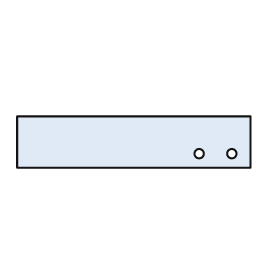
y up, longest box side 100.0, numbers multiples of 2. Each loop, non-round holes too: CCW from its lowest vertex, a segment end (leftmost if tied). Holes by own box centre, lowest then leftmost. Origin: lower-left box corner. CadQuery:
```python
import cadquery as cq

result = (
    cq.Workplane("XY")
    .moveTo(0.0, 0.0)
    .lineTo(100.0, 0.0)
    .lineTo(100.0, 22.0)
    .lineTo(0.0, 22.0)
    .close()
    .moveTo(78.0, 6.0)
    .circle(2.0)
    .moveTo(92.0, 6.0)
    .circle(2.0)
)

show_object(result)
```